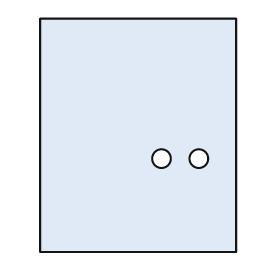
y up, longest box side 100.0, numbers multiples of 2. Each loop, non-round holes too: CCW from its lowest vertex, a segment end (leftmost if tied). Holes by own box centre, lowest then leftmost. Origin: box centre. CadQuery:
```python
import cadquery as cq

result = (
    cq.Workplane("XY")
    .moveTo(-42.0, -50.0)
    .lineTo(42.0, -50.0)
    .lineTo(42.0, 50.0)
    .lineTo(-42.0, 50.0)
    .close()
    .moveTo(10.0, -10.0)
    .circle(4.0)
    .moveTo(26.0, -10.0)
    .circle(4.0)
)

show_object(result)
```